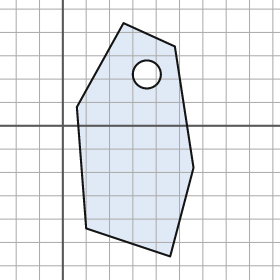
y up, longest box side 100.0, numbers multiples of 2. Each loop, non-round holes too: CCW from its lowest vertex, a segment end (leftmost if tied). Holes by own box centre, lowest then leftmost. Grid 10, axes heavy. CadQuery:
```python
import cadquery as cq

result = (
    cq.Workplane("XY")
    .moveTo(46.0, -56.0)
    .lineTo(56.0, -18.0)
    .lineTo(48.0, 34.0)
    .lineTo(26.0, 44.0)
    .lineTo(6.0, 8.0)
    .lineTo(10.0, -44.0)
    .close()
    .moveTo(36.0, 22.0)
    .circle(6.0)
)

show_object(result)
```